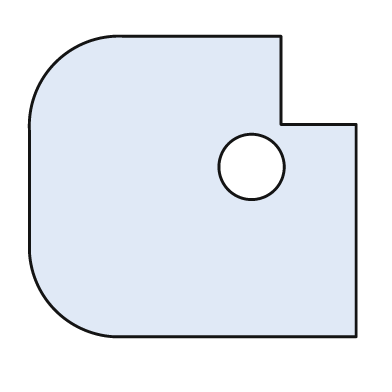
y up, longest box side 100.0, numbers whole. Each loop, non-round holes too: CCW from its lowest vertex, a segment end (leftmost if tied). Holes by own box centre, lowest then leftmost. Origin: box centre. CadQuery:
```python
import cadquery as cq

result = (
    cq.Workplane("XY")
    .moveTo(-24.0, -46.0)
    .lineTo(50.0, -46.0)
    .lineTo(50.0, 19.0)
    .lineTo(27.0, 19.0)
    .lineTo(27.0, 46.0)
    .lineTo(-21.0, 46.0)
    .threePointArc((-42.0, 38.0), (-50.0, 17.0))
    .lineTo(-50.0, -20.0)
    .threePointArc((-42.0, -38.0), (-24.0, -46.0))
    .close()
    .moveTo(18.0, 6.0)
    .circle(10.0)
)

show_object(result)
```